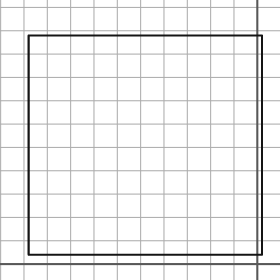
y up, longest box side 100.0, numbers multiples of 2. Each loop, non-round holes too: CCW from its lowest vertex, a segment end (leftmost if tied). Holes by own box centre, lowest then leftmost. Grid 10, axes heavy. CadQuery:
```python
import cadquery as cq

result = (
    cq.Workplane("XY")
    .moveTo(-98.0, 4.0)
    .lineTo(2.0, 4.0)
    .lineTo(2.0, 98.0)
    .lineTo(-98.0, 98.0)
    .close()
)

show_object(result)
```